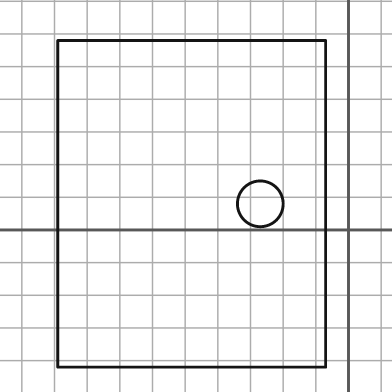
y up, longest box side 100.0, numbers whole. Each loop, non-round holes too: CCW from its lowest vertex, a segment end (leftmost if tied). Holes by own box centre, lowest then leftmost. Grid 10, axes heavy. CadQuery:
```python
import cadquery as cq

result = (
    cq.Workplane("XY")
    .moveTo(-89.0, -42.0)
    .lineTo(-7.0, -42.0)
    .lineTo(-7.0, 58.0)
    .lineTo(-89.0, 58.0)
    .close()
    .moveTo(-27.0, 8.0)
    .circle(7.0)
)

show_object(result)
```